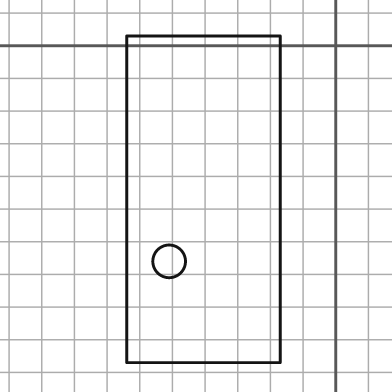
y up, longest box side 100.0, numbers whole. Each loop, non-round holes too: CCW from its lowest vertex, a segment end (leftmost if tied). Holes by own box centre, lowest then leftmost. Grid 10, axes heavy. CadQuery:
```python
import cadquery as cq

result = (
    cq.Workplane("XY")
    .moveTo(-64.0, -97.0)
    .lineTo(-17.0, -97.0)
    .lineTo(-17.0, 3.0)
    .lineTo(-64.0, 3.0)
    .close()
    .moveTo(-51.0, -66.0)
    .circle(5.0)
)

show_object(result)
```